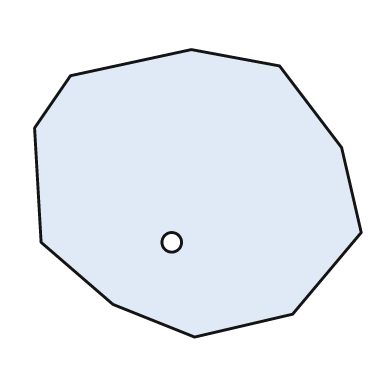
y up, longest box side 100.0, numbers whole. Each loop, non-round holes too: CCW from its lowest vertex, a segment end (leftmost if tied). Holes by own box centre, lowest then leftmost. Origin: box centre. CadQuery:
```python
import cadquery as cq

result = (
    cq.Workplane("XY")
    .moveTo(-1.0, -44.0)
    .lineTo(29.0, -37.0)
    .lineTo(50.0, -12.0)
    .lineTo(44.0, 14.0)
    .lineTo(25.0, 39.0)
    .lineTo(-2.0, 44.0)
    .lineTo(-39.0, 36.0)
    .lineTo(-50.0, 20.0)
    .lineTo(-48.0, -15.0)
    .lineTo(-26.0, -34.0)
    .close()
    .moveTo(-8.0, -15.0)
    .circle(3.0)
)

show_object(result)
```